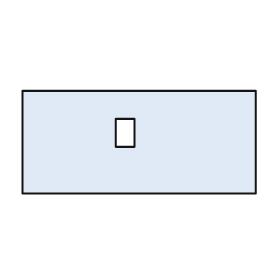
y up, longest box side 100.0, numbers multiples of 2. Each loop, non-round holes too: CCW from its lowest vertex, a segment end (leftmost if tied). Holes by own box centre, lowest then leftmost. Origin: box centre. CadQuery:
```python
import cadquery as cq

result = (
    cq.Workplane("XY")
    .moveTo(-50.0, -22.0)
    .lineTo(50.0, -22.0)
    .lineTo(50.0, 22.0)
    .lineTo(-50.0, 22.0)
    .close()
    .moveTo(-10.0, -2.0)
    .lineTo(-2.0, -2.0)
    .lineTo(-2.0, 10.0)
    .lineTo(-10.0, 10.0)
    .close()
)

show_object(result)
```